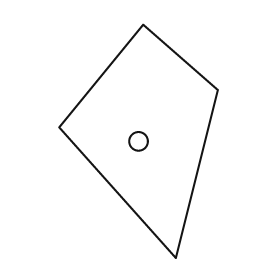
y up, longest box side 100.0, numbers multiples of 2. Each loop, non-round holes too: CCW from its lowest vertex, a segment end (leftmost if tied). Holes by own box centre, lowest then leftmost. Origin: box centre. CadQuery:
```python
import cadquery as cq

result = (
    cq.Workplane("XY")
    .moveTo(16.0, -50.0)
    .lineTo(34.0, 22.0)
    .lineTo(2.0, 50.0)
    .lineTo(-34.0, 6.0)
    .close()
    .moveTo(0.0, 0.0)
    .circle(4.0)
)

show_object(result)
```